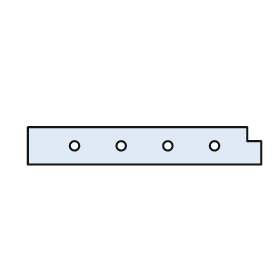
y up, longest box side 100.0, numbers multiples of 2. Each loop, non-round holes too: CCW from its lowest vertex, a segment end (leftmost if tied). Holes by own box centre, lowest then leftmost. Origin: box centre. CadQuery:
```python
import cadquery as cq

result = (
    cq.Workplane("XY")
    .moveTo(-50.0, -8.0)
    .lineTo(50.0, -8.0)
    .lineTo(50.0, 2.0)
    .lineTo(44.0, 2.0)
    .lineTo(44.0, 8.0)
    .lineTo(-50.0, 8.0)
    .close()
    .moveTo(-30.0, 0.0)
    .circle(2.0)
    .moveTo(-10.0, 0.0)
    .circle(2.0)
    .moveTo(10.0, 0.0)
    .circle(2.0)
    .moveTo(30.0, 0.0)
    .circle(2.0)
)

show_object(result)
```